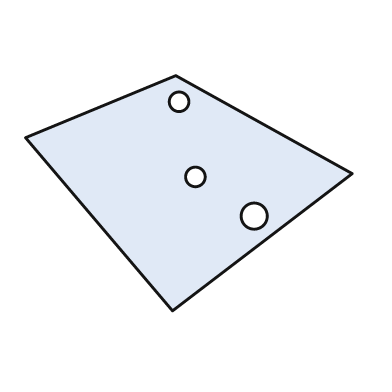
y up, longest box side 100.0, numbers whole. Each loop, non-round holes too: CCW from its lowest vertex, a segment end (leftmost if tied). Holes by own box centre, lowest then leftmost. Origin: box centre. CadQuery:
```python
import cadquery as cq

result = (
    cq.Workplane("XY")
    .moveTo(-5.0, -36.0)
    .lineTo(50.0, 6.0)
    .lineTo(-4.0, 36.0)
    .lineTo(-50.0, 17.0)
    .close()
    .moveTo(20.0, -7.0)
    .circle(4.0)
    .moveTo(2.0, 5.0)
    .circle(3.0)
    .moveTo(-3.0, 28.0)
    .circle(3.0)
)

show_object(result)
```